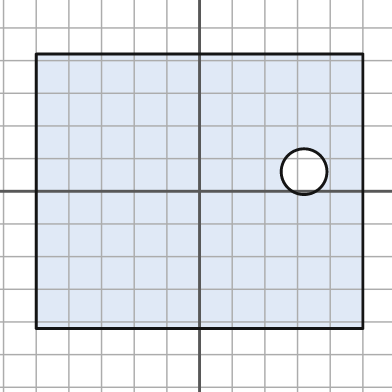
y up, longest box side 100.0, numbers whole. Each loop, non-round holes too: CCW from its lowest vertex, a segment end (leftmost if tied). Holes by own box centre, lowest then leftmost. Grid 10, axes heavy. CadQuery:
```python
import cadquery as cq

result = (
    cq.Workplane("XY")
    .moveTo(-50.0, -42.0)
    .lineTo(50.0, -42.0)
    .lineTo(50.0, 42.0)
    .lineTo(-50.0, 42.0)
    .close()
    .moveTo(32.0, 6.0)
    .circle(7.0)
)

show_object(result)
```